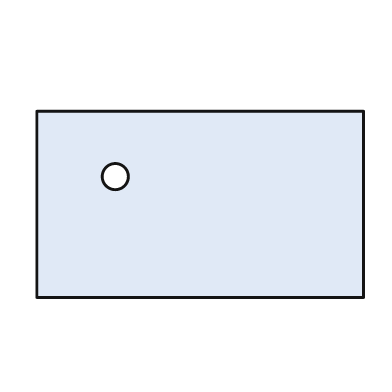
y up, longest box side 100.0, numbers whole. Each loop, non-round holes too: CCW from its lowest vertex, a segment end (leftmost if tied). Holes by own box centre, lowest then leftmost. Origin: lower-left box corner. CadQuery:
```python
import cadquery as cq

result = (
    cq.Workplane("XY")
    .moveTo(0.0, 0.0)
    .lineTo(100.0, 0.0)
    .lineTo(100.0, 57.0)
    .lineTo(0.0, 57.0)
    .close()
    .moveTo(24.0, 37.0)
    .circle(4.0)
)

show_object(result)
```